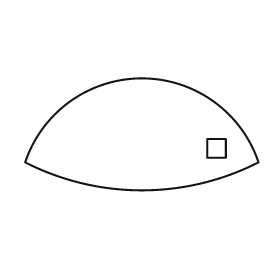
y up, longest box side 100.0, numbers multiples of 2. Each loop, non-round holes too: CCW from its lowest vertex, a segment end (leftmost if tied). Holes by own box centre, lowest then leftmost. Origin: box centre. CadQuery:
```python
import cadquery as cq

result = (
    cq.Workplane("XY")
    .moveTo(-50.0, -12.0)
    .threePointArc((0.0, -24.0), (50.0, -12.0))
    .threePointArc((0.0, 24.0), (-50.0, -12.0))
    .close()
    .moveTo(28.0, -10.0)
    .lineTo(36.0, -10.0)
    .lineTo(36.0, -2.0)
    .lineTo(28.0, -2.0)
    .close()
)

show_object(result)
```